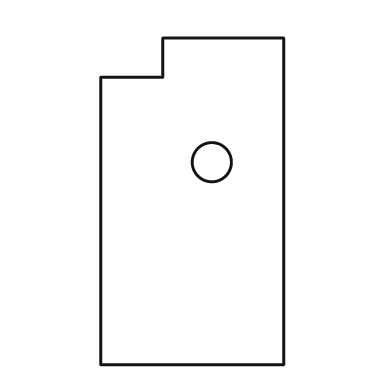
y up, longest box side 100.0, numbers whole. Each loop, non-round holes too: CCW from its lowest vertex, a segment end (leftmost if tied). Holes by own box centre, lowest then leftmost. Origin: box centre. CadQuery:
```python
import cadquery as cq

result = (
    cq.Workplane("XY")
    .moveTo(-28.0, -50.0)
    .lineTo(28.0, -50.0)
    .lineTo(28.0, 50.0)
    .lineTo(-9.0, 50.0)
    .lineTo(-9.0, 38.0)
    .lineTo(-28.0, 38.0)
    .close()
    .moveTo(6.0, 12.0)
    .circle(6.0)
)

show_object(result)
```